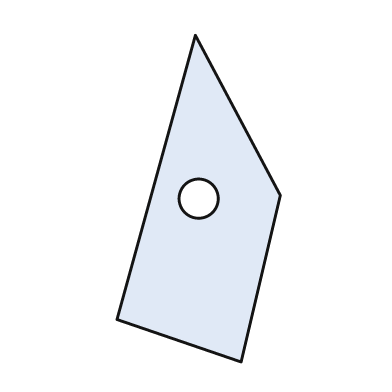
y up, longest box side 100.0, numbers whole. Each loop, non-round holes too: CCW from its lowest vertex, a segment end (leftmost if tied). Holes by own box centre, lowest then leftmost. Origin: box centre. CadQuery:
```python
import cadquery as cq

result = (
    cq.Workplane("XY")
    .moveTo(13.0, -50.0)
    .lineTo(25.0, 1.0)
    .lineTo(-1.0, 50.0)
    .lineTo(-25.0, -37.0)
    .close()
    .moveTo(0.0, 0.0)
    .circle(6.0)
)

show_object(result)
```